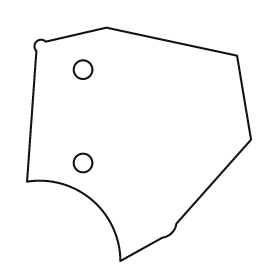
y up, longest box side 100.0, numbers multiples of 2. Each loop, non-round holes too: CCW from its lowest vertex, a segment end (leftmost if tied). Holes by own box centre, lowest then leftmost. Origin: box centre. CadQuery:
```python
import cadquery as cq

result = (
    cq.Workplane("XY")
    .moveTo(-8.0, -50.0)
    .lineTo(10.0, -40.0)
    .threePointArc((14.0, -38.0), (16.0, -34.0))
    .lineTo(48.0, 2.0)
    .lineTo(42.0, 38.0)
    .lineTo(-14.0, 50.0)
    .lineTo(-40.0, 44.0)
    .threePointArc((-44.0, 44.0), (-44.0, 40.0))
    .lineTo(-48.0, -16.0)
    .threePointArc((-20.0, -24.0), (-8.0, -50.0))
    .close()
    .moveTo(-24.0, -8.0)
    .circle(4.0)
    .moveTo(-24.0, 32.0)
    .circle(4.0)
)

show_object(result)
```